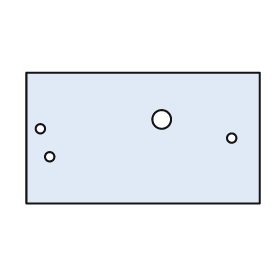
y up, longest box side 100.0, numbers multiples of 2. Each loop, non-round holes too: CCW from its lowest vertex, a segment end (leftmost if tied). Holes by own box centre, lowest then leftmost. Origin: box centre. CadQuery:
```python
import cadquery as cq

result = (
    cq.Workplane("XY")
    .moveTo(-50.0, -28.0)
    .lineTo(50.0, -28.0)
    .lineTo(50.0, 28.0)
    .lineTo(-50.0, 28.0)
    .close()
    .moveTo(-40.0, -8.0)
    .circle(2.0)
    .moveTo(38.0, 0.0)
    .circle(2.0)
    .moveTo(-44.0, 4.0)
    .circle(2.0)
    .moveTo(8.0, 8.0)
    .circle(4.0)
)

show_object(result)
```